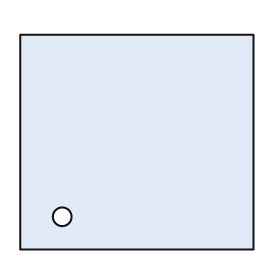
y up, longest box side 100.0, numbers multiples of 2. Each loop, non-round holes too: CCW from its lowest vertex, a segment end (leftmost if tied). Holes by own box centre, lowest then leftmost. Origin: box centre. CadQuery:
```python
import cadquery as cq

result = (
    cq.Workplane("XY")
    .moveTo(-50.0, -46.0)
    .lineTo(50.0, -46.0)
    .lineTo(50.0, 46.0)
    .lineTo(-50.0, 46.0)
    .close()
    .moveTo(-32.0, -32.0)
    .circle(4.0)
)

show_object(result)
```